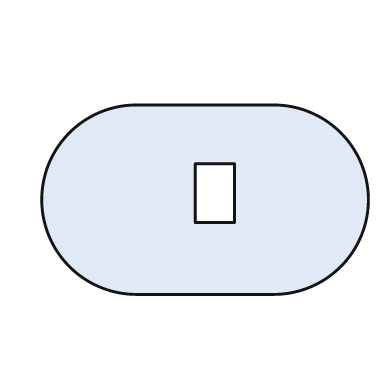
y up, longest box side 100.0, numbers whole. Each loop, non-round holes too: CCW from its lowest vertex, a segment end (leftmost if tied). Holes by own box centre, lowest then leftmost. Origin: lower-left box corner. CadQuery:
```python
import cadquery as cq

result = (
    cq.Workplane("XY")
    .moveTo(29.0, 0.0)
    .lineTo(71.0, 0.0)
    .threePointArc((100.0, 29.0), (71.0, 58.0))
    .lineTo(29.0, 58.0)
    .threePointArc((0.0, 29.0), (29.0, 0.0))
    .close()
    .moveTo(47.0, 22.0)
    .lineTo(59.0, 22.0)
    .lineTo(59.0, 40.0)
    .lineTo(47.0, 40.0)
    .close()
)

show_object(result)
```